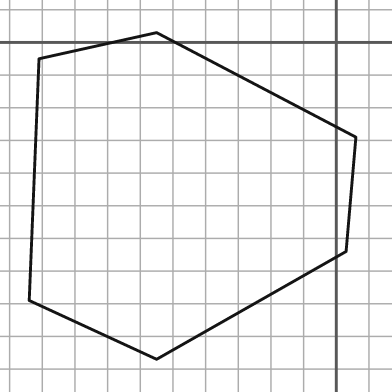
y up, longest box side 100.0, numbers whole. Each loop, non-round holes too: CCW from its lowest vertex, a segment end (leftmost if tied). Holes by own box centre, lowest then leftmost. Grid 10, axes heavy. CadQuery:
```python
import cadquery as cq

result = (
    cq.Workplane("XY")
    .moveTo(-55.0, -97.0)
    .lineTo(3.0, -64.0)
    .lineTo(6.0, -29.0)
    .lineTo(-55.0, 3.0)
    .lineTo(-91.0, -5.0)
    .lineTo(-94.0, -79.0)
    .close()
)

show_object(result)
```